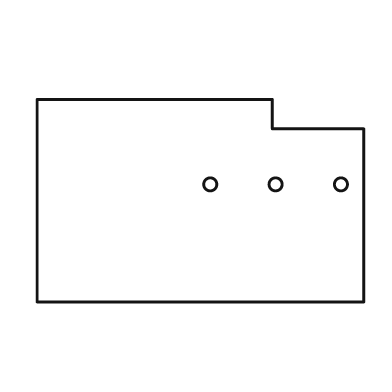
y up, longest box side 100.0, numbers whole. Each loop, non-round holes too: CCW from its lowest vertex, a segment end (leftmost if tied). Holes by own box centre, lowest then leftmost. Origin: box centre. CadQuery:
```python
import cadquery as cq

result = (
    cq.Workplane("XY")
    .moveTo(-50.0, -31.0)
    .lineTo(50.0, -31.0)
    .lineTo(50.0, 22.0)
    .lineTo(22.0, 22.0)
    .lineTo(22.0, 31.0)
    .lineTo(-50.0, 31.0)
    .close()
    .moveTo(3.0, 5.0)
    .circle(2.0)
    .moveTo(23.0, 5.0)
    .circle(2.0)
    .moveTo(43.0, 5.0)
    .circle(2.0)
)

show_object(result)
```